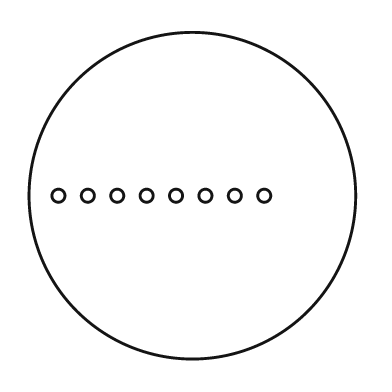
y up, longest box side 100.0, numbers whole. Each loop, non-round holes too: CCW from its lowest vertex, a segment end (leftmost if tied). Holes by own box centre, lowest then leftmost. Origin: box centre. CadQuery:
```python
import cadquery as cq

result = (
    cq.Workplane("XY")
    .moveTo(0.0, 0.0)
    .circle(50.0)
    .moveTo(-41.0, 0.0)
    .circle(2.0)
    .moveTo(-32.0, 0.0)
    .circle(2.0)
    .moveTo(-23.0, 0.0)
    .circle(2.0)
    .moveTo(-14.0, 0.0)
    .circle(2.0)
    .moveTo(-5.0, 0.0)
    .circle(2.0)
    .moveTo(4.0, 0.0)
    .circle(2.0)
    .moveTo(13.0, 0.0)
    .circle(2.0)
    .moveTo(22.0, 0.0)
    .circle(2.0)
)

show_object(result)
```